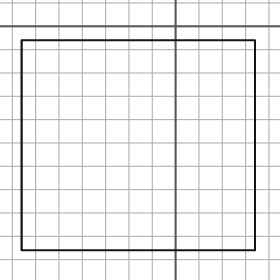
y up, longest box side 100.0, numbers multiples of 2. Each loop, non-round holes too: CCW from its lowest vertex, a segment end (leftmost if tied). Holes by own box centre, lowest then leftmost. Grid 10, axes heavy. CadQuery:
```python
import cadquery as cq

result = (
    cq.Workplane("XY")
    .moveTo(-66.0, -96.0)
    .lineTo(34.0, -96.0)
    .lineTo(34.0, -6.0)
    .lineTo(-66.0, -6.0)
    .close()
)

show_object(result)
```